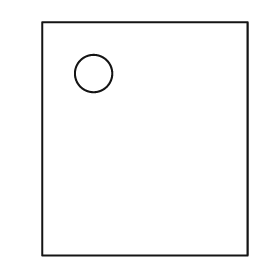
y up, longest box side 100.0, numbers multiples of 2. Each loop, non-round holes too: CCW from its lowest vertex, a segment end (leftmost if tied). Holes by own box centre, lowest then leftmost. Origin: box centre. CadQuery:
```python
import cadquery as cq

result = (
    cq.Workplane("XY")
    .moveTo(-44.0, -50.0)
    .lineTo(44.0, -50.0)
    .lineTo(44.0, 50.0)
    .lineTo(-44.0, 50.0)
    .close()
    .moveTo(-22.0, 28.0)
    .circle(8.0)
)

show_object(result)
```